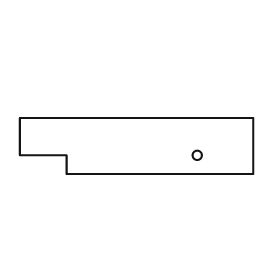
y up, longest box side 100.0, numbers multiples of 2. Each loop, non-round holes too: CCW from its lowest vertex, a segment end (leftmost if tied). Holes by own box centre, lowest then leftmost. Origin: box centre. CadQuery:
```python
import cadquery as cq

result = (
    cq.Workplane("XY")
    .moveTo(-30.0, -12.0)
    .lineTo(50.0, -12.0)
    .lineTo(50.0, 12.0)
    .lineTo(-50.0, 12.0)
    .lineTo(-50.0, -4.0)
    .lineTo(-30.0, -4.0)
    .close()
    .moveTo(26.0, -4.0)
    .circle(2.0)
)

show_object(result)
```